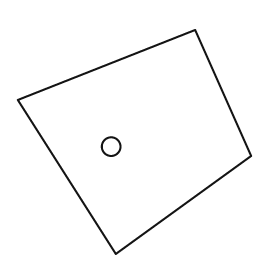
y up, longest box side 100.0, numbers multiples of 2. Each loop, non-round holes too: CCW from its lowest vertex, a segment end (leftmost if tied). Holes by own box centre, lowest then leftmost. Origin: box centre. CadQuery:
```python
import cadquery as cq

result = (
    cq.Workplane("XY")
    .moveTo(-8.0, -48.0)
    .lineTo(50.0, -6.0)
    .lineTo(26.0, 48.0)
    .lineTo(-50.0, 18.0)
    .close()
    .moveTo(-10.0, -2.0)
    .circle(4.0)
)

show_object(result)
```